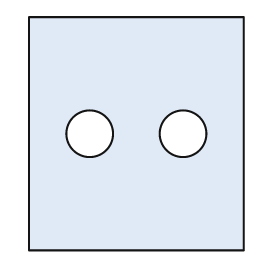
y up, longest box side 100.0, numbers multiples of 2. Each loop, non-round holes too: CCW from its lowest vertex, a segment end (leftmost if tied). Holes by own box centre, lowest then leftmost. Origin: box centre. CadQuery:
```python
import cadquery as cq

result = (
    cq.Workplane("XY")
    .moveTo(-46.0, -50.0)
    .lineTo(46.0, -50.0)
    .lineTo(46.0, 50.0)
    .lineTo(-46.0, 50.0)
    .close()
    .moveTo(-20.0, 0.0)
    .circle(10.0)
    .moveTo(20.0, 0.0)
    .circle(10.0)
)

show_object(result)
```